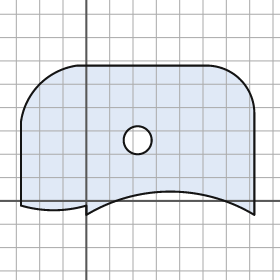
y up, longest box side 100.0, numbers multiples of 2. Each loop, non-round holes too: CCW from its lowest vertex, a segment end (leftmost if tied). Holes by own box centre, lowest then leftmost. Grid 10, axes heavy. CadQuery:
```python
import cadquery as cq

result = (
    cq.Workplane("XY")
    .moveTo(0.0, -6.0)
    .threePointArc((36.0, 4.0), (72.0, -6.0))
    .lineTo(72.0, 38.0)
    .threePointArc((66.0, 52.0), (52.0, 58.0))
    .lineTo(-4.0, 58.0)
    .threePointArc((-20.0, 50.0), (-28.0, 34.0))
    .lineTo(-28.0, -2.0)
    .threePointArc((-14.0, -4.0), (0.0, -2.0))
    .close()
    .moveTo(22.0, 26.0)
    .circle(6.0)
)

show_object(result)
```